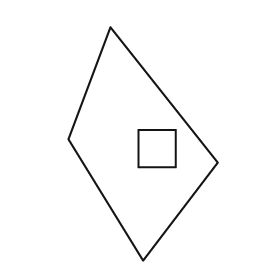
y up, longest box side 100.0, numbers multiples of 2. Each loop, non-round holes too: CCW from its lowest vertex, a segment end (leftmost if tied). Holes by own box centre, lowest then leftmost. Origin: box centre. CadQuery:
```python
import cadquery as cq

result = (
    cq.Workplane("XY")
    .moveTo(0.0, -50.0)
    .lineTo(32.0, -8.0)
    .lineTo(-14.0, 50.0)
    .lineTo(-32.0, 2.0)
    .close()
    .moveTo(-2.0, -10.0)
    .lineTo(14.0, -10.0)
    .lineTo(14.0, 6.0)
    .lineTo(-2.0, 6.0)
    .close()
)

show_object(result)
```